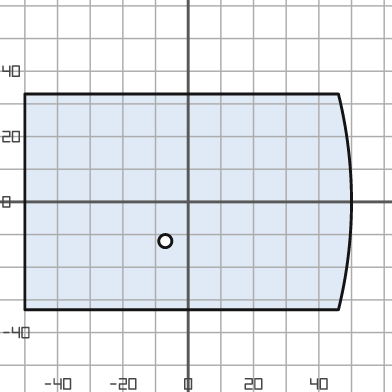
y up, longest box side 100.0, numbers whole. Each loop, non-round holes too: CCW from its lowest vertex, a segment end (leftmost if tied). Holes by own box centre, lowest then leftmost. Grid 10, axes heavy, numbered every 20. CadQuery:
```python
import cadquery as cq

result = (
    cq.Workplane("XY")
    .moveTo(-50.0, -33.0)
    .lineTo(46.0, -33.0)
    .threePointArc((50.0, 0.0), (46.0, 33.0))
    .lineTo(-50.0, 33.0)
    .close()
    .moveTo(-7.0, -12.0)
    .circle(2.0)
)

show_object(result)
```